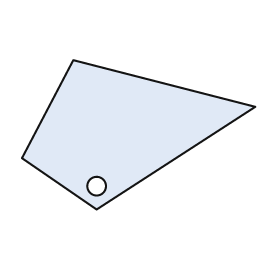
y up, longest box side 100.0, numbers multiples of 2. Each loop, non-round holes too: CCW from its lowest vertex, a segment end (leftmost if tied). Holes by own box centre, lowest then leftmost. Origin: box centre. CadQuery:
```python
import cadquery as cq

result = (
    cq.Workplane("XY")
    .moveTo(-18.0, -32.0)
    .lineTo(50.0, 12.0)
    .lineTo(-28.0, 32.0)
    .lineTo(-50.0, -10.0)
    .close()
    .moveTo(-18.0, -22.0)
    .circle(4.0)
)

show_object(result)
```